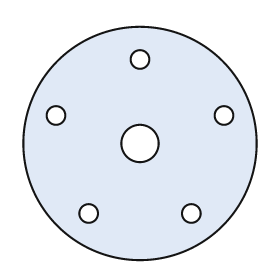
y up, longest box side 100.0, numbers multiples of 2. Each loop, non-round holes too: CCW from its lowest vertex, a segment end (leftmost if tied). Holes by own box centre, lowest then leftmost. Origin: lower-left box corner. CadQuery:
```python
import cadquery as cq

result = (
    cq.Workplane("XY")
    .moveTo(50.0, 50.0)
    .circle(50.0)
    .moveTo(28.0, 20.0)
    .circle(4.0)
    .moveTo(72.0, 20.0)
    .circle(4.0)
    .moveTo(50.0, 50.0)
    .circle(8.0)
    .moveTo(14.0, 62.0)
    .circle(4.0)
    .moveTo(86.0, 62.0)
    .circle(4.0)
    .moveTo(50.0, 86.0)
    .circle(4.0)
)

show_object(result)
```